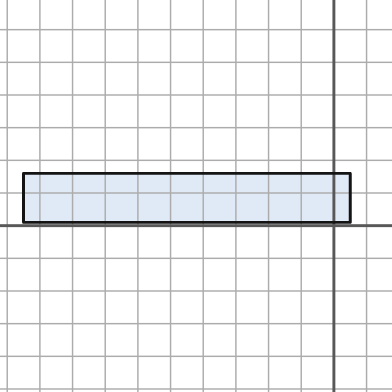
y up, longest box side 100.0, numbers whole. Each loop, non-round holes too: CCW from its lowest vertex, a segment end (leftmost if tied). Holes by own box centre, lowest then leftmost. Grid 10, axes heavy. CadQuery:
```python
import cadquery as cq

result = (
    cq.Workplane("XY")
    .moveTo(-95.0, 1.0)
    .lineTo(5.0, 1.0)
    .lineTo(5.0, 16.0)
    .lineTo(-95.0, 16.0)
    .close()
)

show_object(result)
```